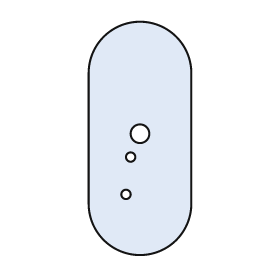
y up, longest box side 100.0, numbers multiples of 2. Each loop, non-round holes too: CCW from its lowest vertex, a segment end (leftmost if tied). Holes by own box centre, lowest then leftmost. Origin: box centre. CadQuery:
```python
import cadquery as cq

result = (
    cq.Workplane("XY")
    .moveTo(-22.0, -28.0)
    .threePointArc((0.0, -50.0), (22.0, -28.0))
    .lineTo(22.0, 28.0)
    .threePointArc((0.0, 50.0), (-22.0, 28.0))
    .close()
    .moveTo(-6.0, -24.0)
    .circle(2.0)
    .moveTo(-4.0, -8.0)
    .circle(2.0)
    .moveTo(0.0, 2.0)
    .circle(4.0)
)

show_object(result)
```